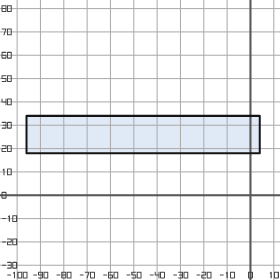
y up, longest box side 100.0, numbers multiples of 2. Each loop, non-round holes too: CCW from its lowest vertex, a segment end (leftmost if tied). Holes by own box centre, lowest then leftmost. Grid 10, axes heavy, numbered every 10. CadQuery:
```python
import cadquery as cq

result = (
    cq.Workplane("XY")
    .moveTo(-96.0, 18.0)
    .lineTo(4.0, 18.0)
    .lineTo(4.0, 34.0)
    .lineTo(-96.0, 34.0)
    .close()
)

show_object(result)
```